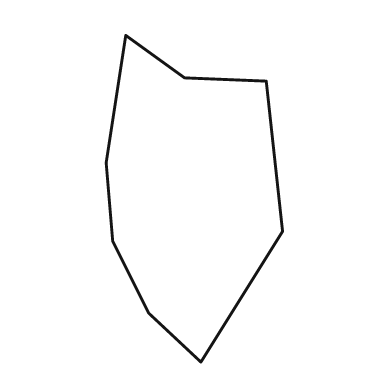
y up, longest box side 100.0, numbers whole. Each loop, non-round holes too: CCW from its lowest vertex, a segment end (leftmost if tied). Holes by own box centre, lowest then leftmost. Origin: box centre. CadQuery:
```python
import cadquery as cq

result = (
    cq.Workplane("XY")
    .moveTo(2.0, -50.0)
    .lineTo(27.0, -10.0)
    .lineTo(22.0, 36.0)
    .lineTo(-3.0, 37.0)
    .lineTo(-21.0, 50.0)
    .lineTo(-27.0, 11.0)
    .lineTo(-25.0, -13.0)
    .lineTo(-14.0, -35.0)
    .close()
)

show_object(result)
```